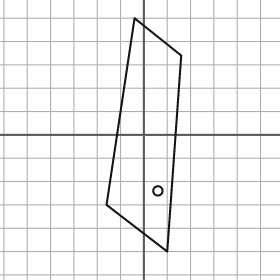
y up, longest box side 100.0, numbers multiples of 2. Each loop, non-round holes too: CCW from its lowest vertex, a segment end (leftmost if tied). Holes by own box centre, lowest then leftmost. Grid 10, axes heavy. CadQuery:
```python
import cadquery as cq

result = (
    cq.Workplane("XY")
    .moveTo(10.0, -50.0)
    .lineTo(16.0, 34.0)
    .lineTo(-4.0, 50.0)
    .lineTo(-16.0, -30.0)
    .close()
    .moveTo(6.0, -24.0)
    .circle(2.0)
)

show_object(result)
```